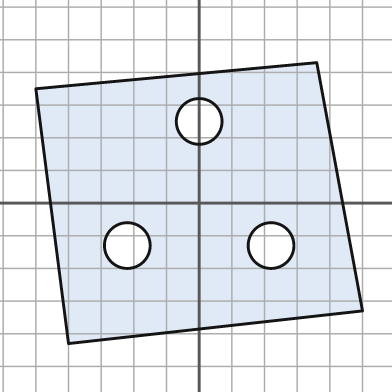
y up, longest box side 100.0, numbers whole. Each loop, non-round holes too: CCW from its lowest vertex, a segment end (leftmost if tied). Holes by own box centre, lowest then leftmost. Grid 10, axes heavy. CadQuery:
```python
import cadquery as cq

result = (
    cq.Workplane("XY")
    .moveTo(-40.0, -43.0)
    .lineTo(50.0, -33.0)
    .lineTo(36.0, 43.0)
    .lineTo(-50.0, 35.0)
    .close()
    .moveTo(-22.0, -13.0)
    .circle(7.0)
    .moveTo(22.0, -13.0)
    .circle(7.0)
    .moveTo(0.0, 25.0)
    .circle(7.0)
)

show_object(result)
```